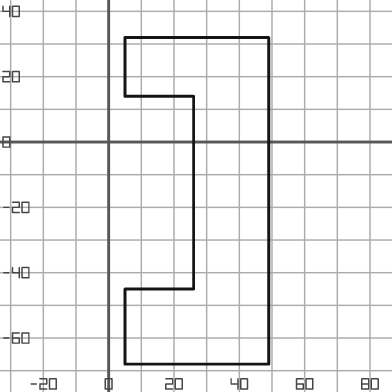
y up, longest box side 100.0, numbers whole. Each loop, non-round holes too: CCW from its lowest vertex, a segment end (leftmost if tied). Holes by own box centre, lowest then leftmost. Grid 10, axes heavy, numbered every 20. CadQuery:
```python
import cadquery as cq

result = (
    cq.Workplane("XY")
    .moveTo(5.0, -68.0)
    .lineTo(49.0, -68.0)
    .lineTo(49.0, 32.0)
    .lineTo(5.0, 32.0)
    .lineTo(5.0, 14.0)
    .lineTo(26.0, 14.0)
    .lineTo(26.0, -45.0)
    .lineTo(5.0, -45.0)
    .close()
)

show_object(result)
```